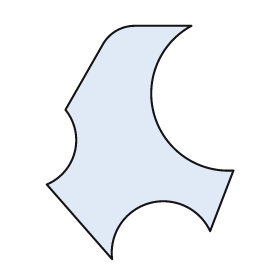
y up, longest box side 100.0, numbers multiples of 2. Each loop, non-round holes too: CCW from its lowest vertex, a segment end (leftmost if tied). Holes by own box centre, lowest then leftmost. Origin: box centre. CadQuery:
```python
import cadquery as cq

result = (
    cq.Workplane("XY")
    .moveTo(-12.0, -50.0)
    .threePointArc((4.0, -26.0), (30.0, -38.0))
    .lineTo(40.0, -12.0)
    .threePointArc((6.0, 12.0), (22.0, 50.0))
    .lineTo(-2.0, 50.0)
    .threePointArc((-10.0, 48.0), (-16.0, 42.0))
    .lineTo(-32.0, 14.0)
    .threePointArc((-28.0, -4.0), (-40.0, -18.0))
    .close()
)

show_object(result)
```